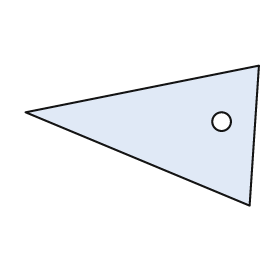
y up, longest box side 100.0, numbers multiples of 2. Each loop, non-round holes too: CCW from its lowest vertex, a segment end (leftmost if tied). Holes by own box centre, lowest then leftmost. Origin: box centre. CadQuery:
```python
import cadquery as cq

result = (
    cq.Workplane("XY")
    .moveTo(46.0, -30.0)
    .lineTo(50.0, 30.0)
    .lineTo(-50.0, 10.0)
    .close()
    .moveTo(34.0, 6.0)
    .circle(4.0)
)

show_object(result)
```